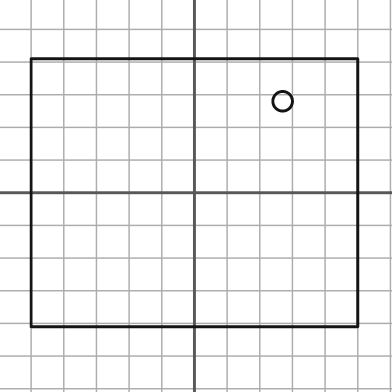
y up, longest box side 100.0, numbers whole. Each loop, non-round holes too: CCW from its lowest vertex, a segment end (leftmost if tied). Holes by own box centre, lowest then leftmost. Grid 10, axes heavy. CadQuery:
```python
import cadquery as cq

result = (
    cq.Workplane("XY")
    .moveTo(-50.0, -41.0)
    .lineTo(50.0, -41.0)
    .lineTo(50.0, 41.0)
    .lineTo(-50.0, 41.0)
    .close()
    .moveTo(27.0, 28.0)
    .circle(3.0)
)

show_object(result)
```